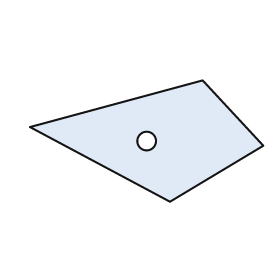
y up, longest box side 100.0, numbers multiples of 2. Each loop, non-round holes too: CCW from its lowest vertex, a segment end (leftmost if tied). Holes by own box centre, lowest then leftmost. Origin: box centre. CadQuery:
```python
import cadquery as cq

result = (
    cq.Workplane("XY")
    .moveTo(10.0, -26.0)
    .lineTo(50.0, -2.0)
    .lineTo(24.0, 26.0)
    .lineTo(-50.0, 6.0)
    .close()
    .moveTo(0.0, 0.0)
    .circle(4.0)
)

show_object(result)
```